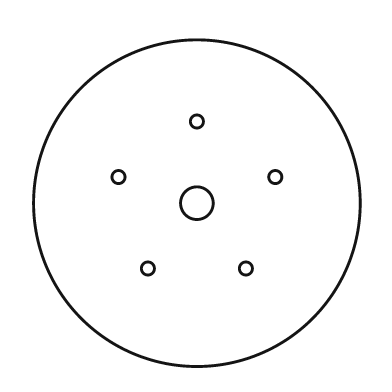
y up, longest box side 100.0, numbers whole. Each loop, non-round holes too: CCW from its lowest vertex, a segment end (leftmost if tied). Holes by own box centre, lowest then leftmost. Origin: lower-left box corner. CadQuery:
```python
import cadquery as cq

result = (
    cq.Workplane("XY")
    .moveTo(50.0, 50.0)
    .circle(50.0)
    .moveTo(35.0, 30.0)
    .circle(2.0)
    .moveTo(65.0, 30.0)
    .circle(2.0)
    .moveTo(50.0, 50.0)
    .circle(5.0)
    .moveTo(26.0, 58.0)
    .circle(2.0)
    .moveTo(74.0, 58.0)
    .circle(2.0)
    .moveTo(50.0, 75.0)
    .circle(2.0)
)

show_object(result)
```